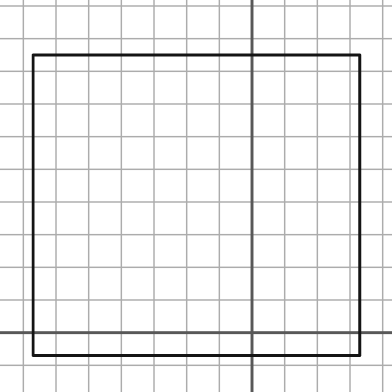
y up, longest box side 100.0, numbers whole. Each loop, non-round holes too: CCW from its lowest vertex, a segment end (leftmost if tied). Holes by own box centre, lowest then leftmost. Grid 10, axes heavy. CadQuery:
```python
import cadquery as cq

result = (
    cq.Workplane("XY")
    .moveTo(-67.0, -7.0)
    .lineTo(33.0, -7.0)
    .lineTo(33.0, 85.0)
    .lineTo(-67.0, 85.0)
    .close()
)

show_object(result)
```